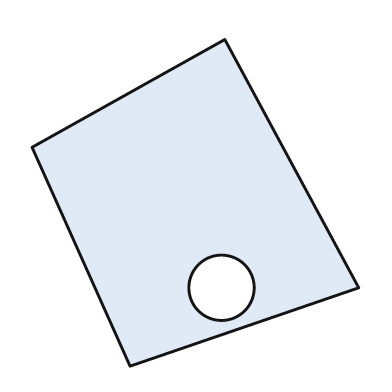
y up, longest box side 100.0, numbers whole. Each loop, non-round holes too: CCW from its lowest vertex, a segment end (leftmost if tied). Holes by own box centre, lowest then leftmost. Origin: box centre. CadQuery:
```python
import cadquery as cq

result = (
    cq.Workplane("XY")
    .moveTo(-20.0, -50.0)
    .lineTo(50.0, -26.0)
    .lineTo(9.0, 50.0)
    .lineTo(-50.0, 17.0)
    .close()
    .moveTo(8.0, -26.0)
    .circle(10.0)
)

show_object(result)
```